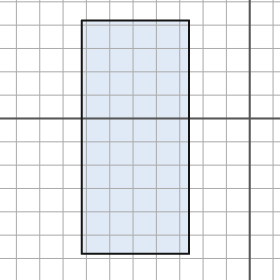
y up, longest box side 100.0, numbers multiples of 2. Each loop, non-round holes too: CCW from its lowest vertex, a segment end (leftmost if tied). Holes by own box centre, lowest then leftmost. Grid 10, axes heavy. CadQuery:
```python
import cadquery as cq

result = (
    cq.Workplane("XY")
    .moveTo(-72.0, -58.0)
    .lineTo(-26.0, -58.0)
    .lineTo(-26.0, 42.0)
    .lineTo(-72.0, 42.0)
    .close()
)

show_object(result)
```